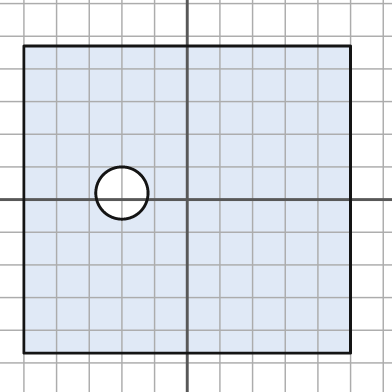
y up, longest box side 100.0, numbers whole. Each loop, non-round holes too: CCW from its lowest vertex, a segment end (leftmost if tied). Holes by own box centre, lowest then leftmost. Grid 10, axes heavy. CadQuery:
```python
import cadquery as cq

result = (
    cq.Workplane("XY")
    .moveTo(-50.0, -47.0)
    .lineTo(50.0, -47.0)
    .lineTo(50.0, 47.0)
    .lineTo(-50.0, 47.0)
    .close()
    .moveTo(-20.0, 2.0)
    .circle(8.0)
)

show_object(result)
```